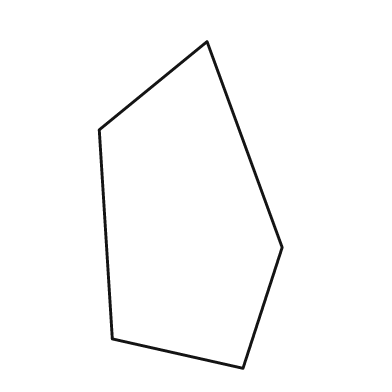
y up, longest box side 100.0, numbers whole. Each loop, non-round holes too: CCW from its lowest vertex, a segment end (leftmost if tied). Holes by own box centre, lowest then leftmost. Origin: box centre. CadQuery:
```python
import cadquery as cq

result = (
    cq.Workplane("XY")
    .moveTo(16.0, -50.0)
    .lineTo(28.0, -13.0)
    .lineTo(5.0, 50.0)
    .lineTo(-28.0, 23.0)
    .lineTo(-24.0, -41.0)
    .close()
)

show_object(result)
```